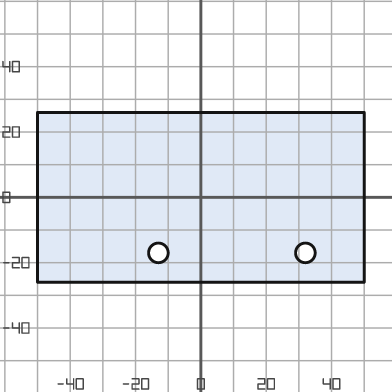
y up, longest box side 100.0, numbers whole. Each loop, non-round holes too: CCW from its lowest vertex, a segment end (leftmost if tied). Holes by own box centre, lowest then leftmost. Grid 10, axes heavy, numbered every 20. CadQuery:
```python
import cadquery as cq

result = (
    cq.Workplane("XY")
    .moveTo(-50.0, -26.0)
    .lineTo(50.0, -26.0)
    .lineTo(50.0, 26.0)
    .lineTo(-50.0, 26.0)
    .close()
    .moveTo(-13.0, -17.0)
    .circle(3.0)
    .moveTo(32.0, -17.0)
    .circle(3.0)
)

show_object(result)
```